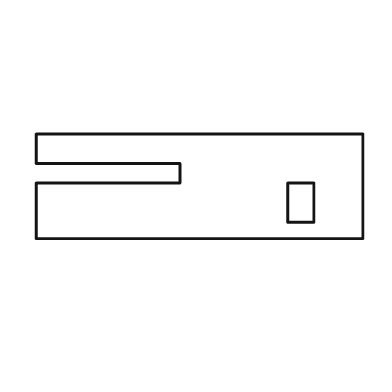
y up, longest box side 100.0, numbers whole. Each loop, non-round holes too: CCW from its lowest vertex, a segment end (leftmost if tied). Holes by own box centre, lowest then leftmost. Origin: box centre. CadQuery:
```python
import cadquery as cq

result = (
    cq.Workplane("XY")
    .moveTo(-50.0, -16.0)
    .lineTo(50.0, -16.0)
    .lineTo(50.0, 16.0)
    .lineTo(-50.0, 16.0)
    .lineTo(-50.0, 7.0)
    .lineTo(-6.0, 7.0)
    .lineTo(-6.0, 1.0)
    .lineTo(-50.0, 1.0)
    .close()
    .moveTo(27.0, -11.0)
    .lineTo(35.0, -11.0)
    .lineTo(35.0, 1.0)
    .lineTo(27.0, 1.0)
    .close()
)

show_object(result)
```